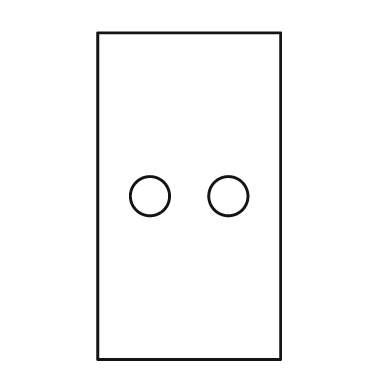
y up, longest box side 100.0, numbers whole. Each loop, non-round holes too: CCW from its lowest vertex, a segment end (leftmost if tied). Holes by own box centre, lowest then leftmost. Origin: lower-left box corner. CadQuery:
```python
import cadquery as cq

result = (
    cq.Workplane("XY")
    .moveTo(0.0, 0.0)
    .lineTo(56.0, 0.0)
    .lineTo(56.0, 100.0)
    .lineTo(0.0, 100.0)
    .close()
    .moveTo(16.0, 50.0)
    .circle(6.0)
    .moveTo(40.0, 50.0)
    .circle(6.0)
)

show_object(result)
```